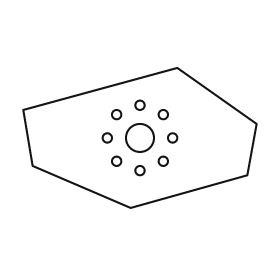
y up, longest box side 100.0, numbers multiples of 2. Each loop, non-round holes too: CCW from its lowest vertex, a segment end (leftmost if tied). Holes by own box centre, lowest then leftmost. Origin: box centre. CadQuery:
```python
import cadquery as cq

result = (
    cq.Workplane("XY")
    .moveTo(-4.0, -30.0)
    .lineTo(46.0, -16.0)
    .lineTo(50.0, 6.0)
    .lineTo(16.0, 30.0)
    .lineTo(-50.0, 12.0)
    .lineTo(-46.0, -12.0)
    .close()
    .moveTo(0.0, -14.0)
    .circle(2.0)
    .moveTo(-10.0, -10.0)
    .circle(2.0)
    .moveTo(10.0, -10.0)
    .circle(2.0)
    .moveTo(-14.0, 0.0)
    .circle(2.0)
    .moveTo(0.0, 0.0)
    .circle(6.0)
    .moveTo(14.0, 0.0)
    .circle(2.0)
    .moveTo(-10.0, 10.0)
    .circle(2.0)
    .moveTo(10.0, 10.0)
    .circle(2.0)
    .moveTo(0.0, 14.0)
    .circle(2.0)
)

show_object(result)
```